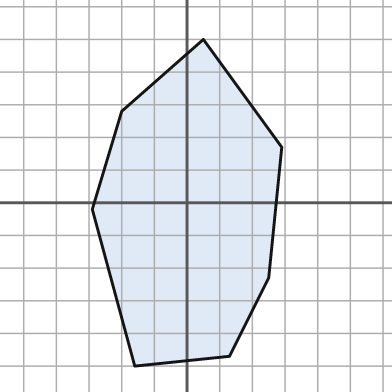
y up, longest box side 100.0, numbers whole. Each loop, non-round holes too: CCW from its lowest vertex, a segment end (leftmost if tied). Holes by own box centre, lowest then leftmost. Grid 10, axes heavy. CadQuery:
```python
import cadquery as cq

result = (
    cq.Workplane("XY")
    .moveTo(-16.0, -50.0)
    .lineTo(13.0, -47.0)
    .lineTo(25.0, -23.0)
    .lineTo(29.0, 17.0)
    .lineTo(5.0, 50.0)
    .lineTo(-20.0, 28.0)
    .lineTo(-29.0, -2.0)
    .close()
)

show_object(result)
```